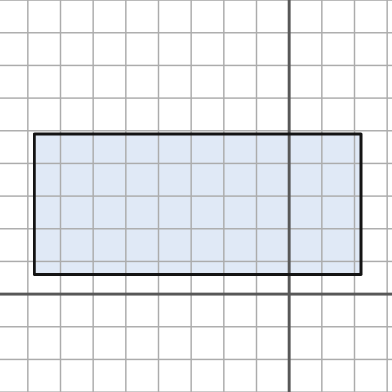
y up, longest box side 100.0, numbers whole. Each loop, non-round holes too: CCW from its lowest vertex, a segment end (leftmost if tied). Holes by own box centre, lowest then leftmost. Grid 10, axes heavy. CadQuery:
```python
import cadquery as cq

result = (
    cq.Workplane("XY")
    .moveTo(-78.0, 6.0)
    .lineTo(22.0, 6.0)
    .lineTo(22.0, 49.0)
    .lineTo(-78.0, 49.0)
    .close()
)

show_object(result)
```